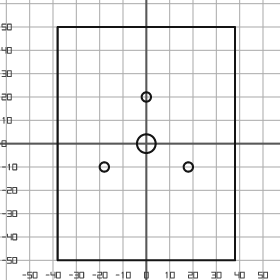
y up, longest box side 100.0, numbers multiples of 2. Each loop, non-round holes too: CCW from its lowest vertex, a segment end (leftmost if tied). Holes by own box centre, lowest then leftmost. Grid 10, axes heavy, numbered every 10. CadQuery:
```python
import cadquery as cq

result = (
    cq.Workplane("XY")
    .moveTo(-38.0, -50.0)
    .lineTo(38.0, -50.0)
    .lineTo(38.0, 50.0)
    .lineTo(-38.0, 50.0)
    .close()
    .moveTo(-18.0, -10.0)
    .circle(2.0)
    .moveTo(18.0, -10.0)
    .circle(2.0)
    .moveTo(0.0, 0.0)
    .circle(4.0)
    .moveTo(0.0, 20.0)
    .circle(2.0)
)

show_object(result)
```